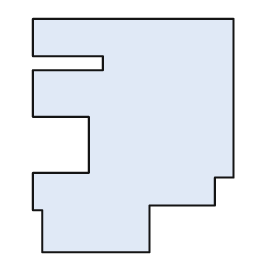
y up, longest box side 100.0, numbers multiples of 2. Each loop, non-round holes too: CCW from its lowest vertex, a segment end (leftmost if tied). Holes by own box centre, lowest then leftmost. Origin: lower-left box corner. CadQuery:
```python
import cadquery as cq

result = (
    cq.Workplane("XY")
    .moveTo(4.0, 0.0)
    .lineTo(50.0, 0.0)
    .lineTo(50.0, 20.0)
    .lineTo(78.0, 20.0)
    .lineTo(78.0, 32.0)
    .lineTo(86.0, 32.0)
    .lineTo(86.0, 100.0)
    .lineTo(0.0, 100.0)
    .lineTo(0.0, 84.0)
    .lineTo(30.0, 84.0)
    .lineTo(30.0, 78.0)
    .lineTo(0.0, 78.0)
    .lineTo(0.0, 58.0)
    .lineTo(24.0, 58.0)
    .lineTo(24.0, 34.0)
    .lineTo(0.0, 34.0)
    .lineTo(0.0, 18.0)
    .lineTo(4.0, 18.0)
    .close()
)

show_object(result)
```